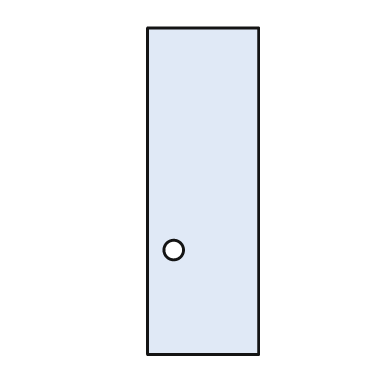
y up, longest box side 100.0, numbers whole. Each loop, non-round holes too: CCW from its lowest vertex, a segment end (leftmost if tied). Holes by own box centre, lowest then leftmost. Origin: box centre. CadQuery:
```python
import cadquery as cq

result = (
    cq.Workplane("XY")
    .moveTo(-17.0, -50.0)
    .lineTo(17.0, -50.0)
    .lineTo(17.0, 50.0)
    .lineTo(-17.0, 50.0)
    .close()
    .moveTo(-9.0, -18.0)
    .circle(3.0)
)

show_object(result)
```